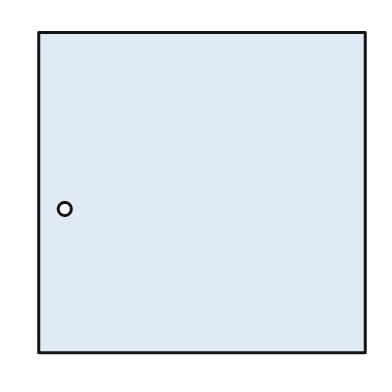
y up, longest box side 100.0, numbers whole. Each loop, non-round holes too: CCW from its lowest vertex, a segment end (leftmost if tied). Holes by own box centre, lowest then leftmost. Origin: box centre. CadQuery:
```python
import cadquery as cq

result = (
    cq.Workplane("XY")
    .moveTo(-50.0, -49.0)
    .lineTo(50.0, -49.0)
    .lineTo(50.0, 49.0)
    .lineTo(-50.0, 49.0)
    .close()
    .moveTo(-42.0, -5.0)
    .circle(2.0)
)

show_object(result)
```